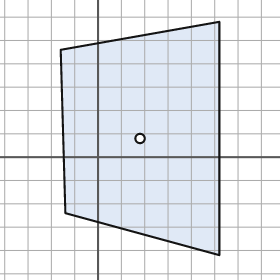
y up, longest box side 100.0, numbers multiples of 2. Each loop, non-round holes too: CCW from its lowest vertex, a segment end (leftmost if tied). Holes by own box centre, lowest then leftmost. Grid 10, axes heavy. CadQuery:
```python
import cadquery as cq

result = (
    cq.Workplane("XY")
    .moveTo(52.0, -42.0)
    .lineTo(52.0, 58.0)
    .lineTo(-16.0, 46.0)
    .lineTo(-14.0, -24.0)
    .close()
    .moveTo(18.0, 8.0)
    .circle(2.0)
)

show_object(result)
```